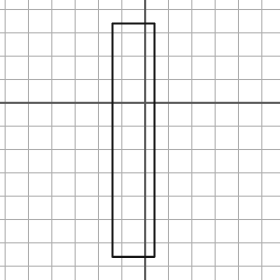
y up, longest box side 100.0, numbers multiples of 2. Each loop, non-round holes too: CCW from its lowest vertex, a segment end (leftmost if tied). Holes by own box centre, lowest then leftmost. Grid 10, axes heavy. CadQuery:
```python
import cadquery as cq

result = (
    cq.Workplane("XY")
    .moveTo(-14.0, -66.0)
    .lineTo(4.0, -66.0)
    .lineTo(4.0, 34.0)
    .lineTo(-14.0, 34.0)
    .close()
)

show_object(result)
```